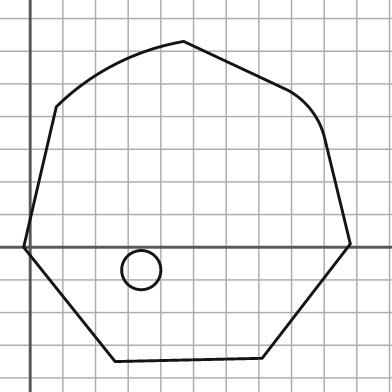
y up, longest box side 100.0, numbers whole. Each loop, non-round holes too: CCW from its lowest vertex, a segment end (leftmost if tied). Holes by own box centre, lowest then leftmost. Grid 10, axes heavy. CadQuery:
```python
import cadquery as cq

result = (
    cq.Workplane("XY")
    .moveTo(26.0, -35.0)
    .lineTo(71.0, -34.0)
    .lineTo(98.0, 1.0)
    .lineTo(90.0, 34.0)
    .threePointArc((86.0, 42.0), (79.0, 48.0))
    .lineTo(47.0, 63.0)
    .threePointArc((26.0, 56.0), (8.0, 43.0))
    .lineTo(-2.0, 0.0)
    .close()
    .moveTo(34.0, -7.0)
    .circle(6.0)
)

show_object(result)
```